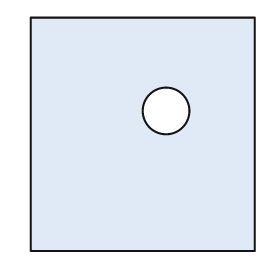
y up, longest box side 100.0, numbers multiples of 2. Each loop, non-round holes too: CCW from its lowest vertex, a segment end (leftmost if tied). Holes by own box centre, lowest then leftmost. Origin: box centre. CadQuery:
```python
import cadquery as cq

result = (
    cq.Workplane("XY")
    .moveTo(-48.0, -50.0)
    .lineTo(48.0, -50.0)
    .lineTo(48.0, 50.0)
    .lineTo(-48.0, 50.0)
    .close()
    .moveTo(10.0, 10.0)
    .circle(10.0)
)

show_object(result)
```